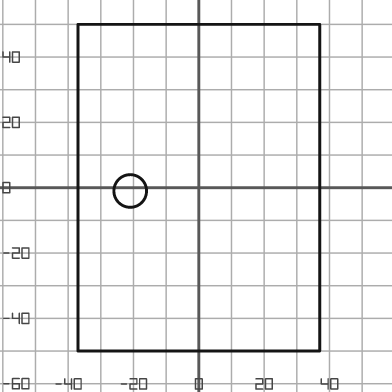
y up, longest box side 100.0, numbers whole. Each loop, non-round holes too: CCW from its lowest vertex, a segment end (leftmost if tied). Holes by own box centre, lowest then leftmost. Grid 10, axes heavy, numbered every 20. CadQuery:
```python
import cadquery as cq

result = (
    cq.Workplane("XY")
    .moveTo(-37.0, -50.0)
    .lineTo(37.0, -50.0)
    .lineTo(37.0, 50.0)
    .lineTo(-37.0, 50.0)
    .close()
    .moveTo(-21.0, -1.0)
    .circle(5.0)
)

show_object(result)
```